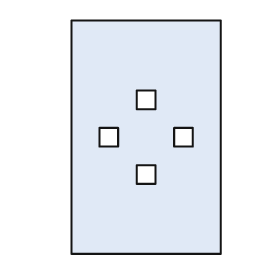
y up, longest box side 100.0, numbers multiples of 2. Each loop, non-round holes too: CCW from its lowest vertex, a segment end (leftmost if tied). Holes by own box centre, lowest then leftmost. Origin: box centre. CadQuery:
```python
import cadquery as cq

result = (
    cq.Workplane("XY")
    .moveTo(-32.0, -50.0)
    .lineTo(32.0, -50.0)
    .lineTo(32.0, 50.0)
    .lineTo(-32.0, 50.0)
    .close()
    .moveTo(-4.0, -20.0)
    .lineTo(4.0, -20.0)
    .lineTo(4.0, -12.0)
    .lineTo(-4.0, -12.0)
    .close()
    .moveTo(-20.0, -4.0)
    .lineTo(-12.0, -4.0)
    .lineTo(-12.0, 4.0)
    .lineTo(-20.0, 4.0)
    .close()
    .moveTo(12.0, -4.0)
    .lineTo(20.0, -4.0)
    .lineTo(20.0, 4.0)
    .lineTo(12.0, 4.0)
    .close()
    .moveTo(-4.0, 12.0)
    .lineTo(4.0, 12.0)
    .lineTo(4.0, 20.0)
    .lineTo(-4.0, 20.0)
    .close()
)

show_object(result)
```